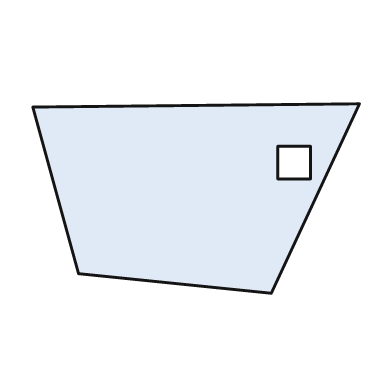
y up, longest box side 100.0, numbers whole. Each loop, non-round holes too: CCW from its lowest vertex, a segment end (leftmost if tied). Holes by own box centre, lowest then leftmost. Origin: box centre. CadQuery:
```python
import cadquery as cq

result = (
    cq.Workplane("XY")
    .moveTo(23.0, -29.0)
    .lineTo(50.0, 29.0)
    .lineTo(-50.0, 28.0)
    .lineTo(-36.0, -23.0)
    .close()
    .moveTo(25.0, 6.0)
    .lineTo(35.0, 6.0)
    .lineTo(35.0, 16.0)
    .lineTo(25.0, 16.0)
    .close()
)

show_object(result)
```